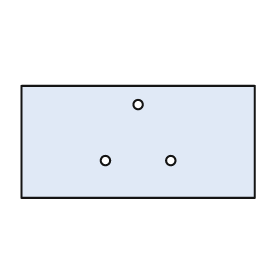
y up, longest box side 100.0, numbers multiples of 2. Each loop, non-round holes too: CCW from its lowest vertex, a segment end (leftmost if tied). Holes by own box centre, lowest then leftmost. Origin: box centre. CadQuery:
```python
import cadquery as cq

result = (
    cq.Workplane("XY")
    .moveTo(-50.0, -24.0)
    .lineTo(50.0, -24.0)
    .lineTo(50.0, 24.0)
    .lineTo(-50.0, 24.0)
    .close()
    .moveTo(-14.0, -8.0)
    .circle(2.0)
    .moveTo(14.0, -8.0)
    .circle(2.0)
    .moveTo(0.0, 16.0)
    .circle(2.0)
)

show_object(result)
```